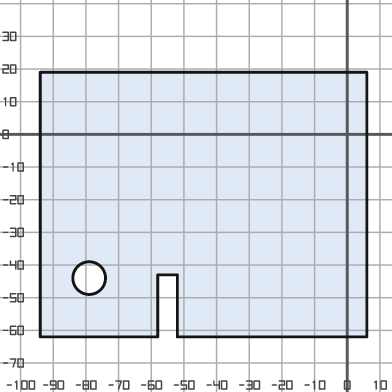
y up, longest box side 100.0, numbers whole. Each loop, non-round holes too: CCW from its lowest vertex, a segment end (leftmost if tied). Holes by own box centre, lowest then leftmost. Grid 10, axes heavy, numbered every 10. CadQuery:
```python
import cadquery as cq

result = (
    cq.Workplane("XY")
    .moveTo(-94.0, -62.0)
    .lineTo(-58.0, -62.0)
    .lineTo(-58.0, -43.0)
    .lineTo(-52.0, -43.0)
    .lineTo(-52.0, -62.0)
    .lineTo(6.0, -62.0)
    .lineTo(6.0, 19.0)
    .lineTo(-94.0, 19.0)
    .close()
    .moveTo(-79.0, -44.0)
    .circle(5.0)
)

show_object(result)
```